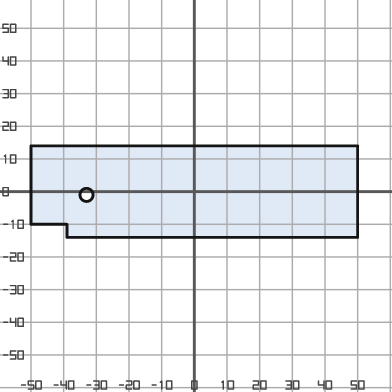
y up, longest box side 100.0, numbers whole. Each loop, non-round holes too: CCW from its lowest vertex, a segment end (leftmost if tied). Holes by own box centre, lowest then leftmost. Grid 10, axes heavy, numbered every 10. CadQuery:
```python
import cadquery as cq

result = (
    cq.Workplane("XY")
    .moveTo(-39.0, -14.0)
    .lineTo(50.0, -14.0)
    .lineTo(50.0, 14.0)
    .lineTo(-50.0, 14.0)
    .lineTo(-50.0, -10.0)
    .lineTo(-39.0, -10.0)
    .close()
    .moveTo(-33.0, -1.0)
    .circle(2.0)
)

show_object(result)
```